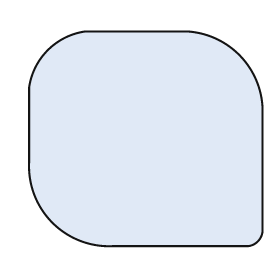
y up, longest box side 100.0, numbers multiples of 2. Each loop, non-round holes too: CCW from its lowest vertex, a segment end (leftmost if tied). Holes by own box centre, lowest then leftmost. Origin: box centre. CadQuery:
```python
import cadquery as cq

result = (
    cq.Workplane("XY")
    .moveTo(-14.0, -46.0)
    .lineTo(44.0, -46.0)
    .threePointArc((48.0, -44.0), (50.0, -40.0))
    .lineTo(50.0, 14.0)
    .threePointArc((40.0, 36.0), (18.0, 46.0))
    .lineTo(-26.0, 46.0)
    .threePointArc((-42.0, 38.0), (-50.0, 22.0))
    .lineTo(-50.0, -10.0)
    .threePointArc((-40.0, -36.0), (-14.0, -46.0))
    .close()
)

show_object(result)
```